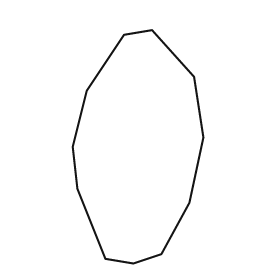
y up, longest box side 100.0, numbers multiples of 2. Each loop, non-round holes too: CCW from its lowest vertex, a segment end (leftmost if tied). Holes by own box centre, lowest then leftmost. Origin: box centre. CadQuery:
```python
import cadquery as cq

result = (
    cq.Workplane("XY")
    .moveTo(-2.0, -50.0)
    .lineTo(10.0, -46.0)
    .lineTo(22.0, -24.0)
    .lineTo(28.0, 4.0)
    .lineTo(24.0, 30.0)
    .lineTo(6.0, 50.0)
    .lineTo(-6.0, 48.0)
    .lineTo(-22.0, 24.0)
    .lineTo(-28.0, 0.0)
    .lineTo(-26.0, -18.0)
    .lineTo(-14.0, -48.0)
    .close()
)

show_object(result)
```